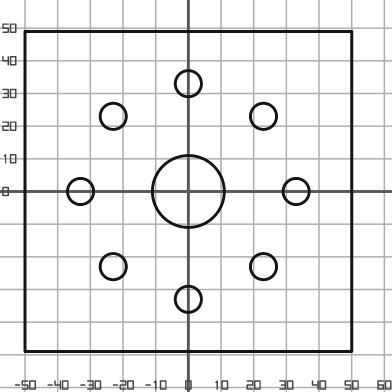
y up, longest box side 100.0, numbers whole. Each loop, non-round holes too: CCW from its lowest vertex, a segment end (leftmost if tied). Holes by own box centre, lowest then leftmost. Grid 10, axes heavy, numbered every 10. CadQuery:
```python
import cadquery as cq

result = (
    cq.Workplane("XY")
    .moveTo(-50.0, -49.0)
    .lineTo(50.0, -49.0)
    .lineTo(50.0, 49.0)
    .lineTo(-50.0, 49.0)
    .close()
    .moveTo(0.0, -33.0)
    .circle(4.0)
    .moveTo(-23.0, -23.0)
    .circle(4.0)
    .moveTo(23.0, -23.0)
    .circle(4.0)
    .moveTo(-33.0, 0.0)
    .circle(4.0)
    .moveTo(0.0, 0.0)
    .circle(11.0)
    .moveTo(33.0, 0.0)
    .circle(4.0)
    .moveTo(-23.0, 23.0)
    .circle(4.0)
    .moveTo(23.0, 23.0)
    .circle(4.0)
    .moveTo(0.0, 33.0)
    .circle(4.0)
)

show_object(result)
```